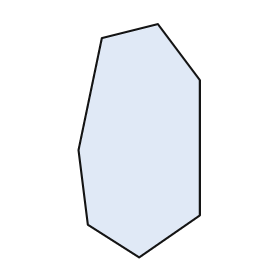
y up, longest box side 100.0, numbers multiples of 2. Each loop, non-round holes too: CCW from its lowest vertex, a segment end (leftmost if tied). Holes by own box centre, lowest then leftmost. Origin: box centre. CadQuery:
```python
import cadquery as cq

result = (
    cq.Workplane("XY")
    .moveTo(0.0, -50.0)
    .lineTo(26.0, -32.0)
    .lineTo(26.0, 26.0)
    .lineTo(8.0, 50.0)
    .lineTo(-16.0, 44.0)
    .lineTo(-26.0, -4.0)
    .lineTo(-22.0, -36.0)
    .close()
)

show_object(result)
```